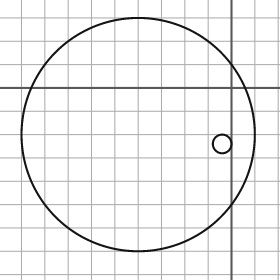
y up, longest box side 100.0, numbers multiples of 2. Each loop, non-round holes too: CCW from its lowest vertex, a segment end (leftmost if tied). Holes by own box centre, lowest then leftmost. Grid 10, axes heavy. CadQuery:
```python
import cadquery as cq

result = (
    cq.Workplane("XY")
    .moveTo(-40.0, -20.0)
    .circle(50.0)
    .moveTo(-4.0, -24.0)
    .circle(4.0)
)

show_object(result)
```